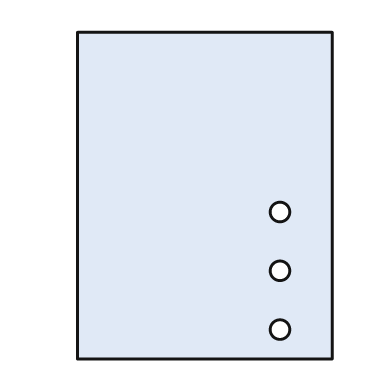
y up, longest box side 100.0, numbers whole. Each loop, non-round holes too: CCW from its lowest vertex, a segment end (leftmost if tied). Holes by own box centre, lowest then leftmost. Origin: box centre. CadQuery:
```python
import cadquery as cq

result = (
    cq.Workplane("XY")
    .moveTo(-39.0, -50.0)
    .lineTo(39.0, -50.0)
    .lineTo(39.0, 50.0)
    .lineTo(-39.0, 50.0)
    .close()
    .moveTo(23.0, -41.0)
    .circle(3.0)
    .moveTo(23.0, -23.0)
    .circle(3.0)
    .moveTo(23.0, -5.0)
    .circle(3.0)
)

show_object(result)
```